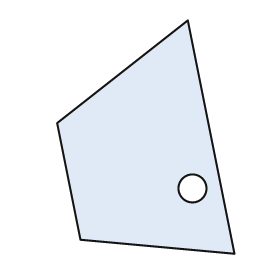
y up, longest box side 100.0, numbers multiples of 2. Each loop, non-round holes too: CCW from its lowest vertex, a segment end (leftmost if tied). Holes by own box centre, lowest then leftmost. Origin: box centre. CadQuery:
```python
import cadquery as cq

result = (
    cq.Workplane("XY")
    .moveTo(38.0, -50.0)
    .lineTo(18.0, 50.0)
    .lineTo(-38.0, 6.0)
    .lineTo(-28.0, -44.0)
    .close()
    .moveTo(20.0, -22.0)
    .circle(6.0)
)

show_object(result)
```